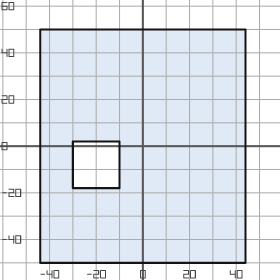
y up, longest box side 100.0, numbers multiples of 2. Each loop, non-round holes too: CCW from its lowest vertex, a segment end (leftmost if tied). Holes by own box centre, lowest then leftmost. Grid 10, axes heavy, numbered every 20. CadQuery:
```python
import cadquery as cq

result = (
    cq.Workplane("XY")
    .moveTo(-44.0, -50.0)
    .lineTo(44.0, -50.0)
    .lineTo(44.0, 50.0)
    .lineTo(-44.0, 50.0)
    .close()
    .moveTo(-30.0, -18.0)
    .lineTo(-10.0, -18.0)
    .lineTo(-10.0, 2.0)
    .lineTo(-30.0, 2.0)
    .close()
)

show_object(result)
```